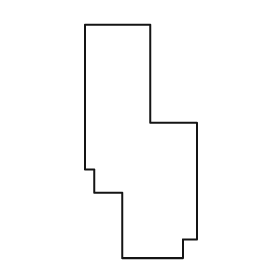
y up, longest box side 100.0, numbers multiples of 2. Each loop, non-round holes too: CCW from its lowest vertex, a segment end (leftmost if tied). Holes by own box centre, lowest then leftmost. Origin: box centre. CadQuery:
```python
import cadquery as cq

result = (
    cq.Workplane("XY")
    .moveTo(-8.0, -50.0)
    .lineTo(18.0, -50.0)
    .lineTo(18.0, -42.0)
    .lineTo(24.0, -42.0)
    .lineTo(24.0, 8.0)
    .lineTo(4.0, 8.0)
    .lineTo(4.0, 50.0)
    .lineTo(-24.0, 50.0)
    .lineTo(-24.0, -12.0)
    .lineTo(-20.0, -12.0)
    .lineTo(-20.0, -22.0)
    .lineTo(-8.0, -22.0)
    .close()
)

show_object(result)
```